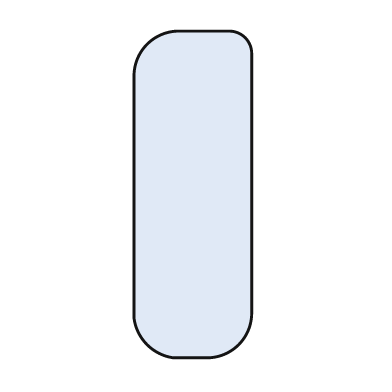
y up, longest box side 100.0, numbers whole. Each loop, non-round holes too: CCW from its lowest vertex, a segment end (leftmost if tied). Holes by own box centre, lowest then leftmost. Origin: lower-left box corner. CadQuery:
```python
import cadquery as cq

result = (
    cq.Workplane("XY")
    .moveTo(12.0, 0.0)
    .lineTo(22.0, 0.0)
    .threePointArc((32.0, 4.0), (36.0, 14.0))
    .lineTo(36.0, 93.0)
    .threePointArc((34.0, 98.0), (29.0, 100.0))
    .lineTo(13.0, 100.0)
    .threePointArc((4.0, 96.0), (0.0, 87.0))
    .lineTo(0.0, 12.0)
    .threePointArc((4.0, 4.0), (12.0, 0.0))
    .close()
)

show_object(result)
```